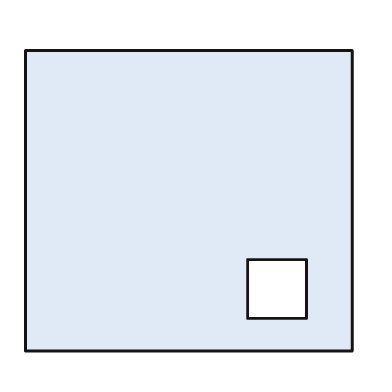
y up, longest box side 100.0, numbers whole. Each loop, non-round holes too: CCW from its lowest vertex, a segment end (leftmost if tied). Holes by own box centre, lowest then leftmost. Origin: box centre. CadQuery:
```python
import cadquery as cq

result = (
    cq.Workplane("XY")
    .moveTo(-50.0, -46.0)
    .lineTo(50.0, -46.0)
    .lineTo(50.0, 46.0)
    .lineTo(-50.0, 46.0)
    .close()
    .moveTo(18.0, -36.0)
    .lineTo(36.0, -36.0)
    .lineTo(36.0, -18.0)
    .lineTo(18.0, -18.0)
    .close()
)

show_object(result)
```